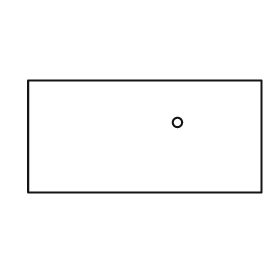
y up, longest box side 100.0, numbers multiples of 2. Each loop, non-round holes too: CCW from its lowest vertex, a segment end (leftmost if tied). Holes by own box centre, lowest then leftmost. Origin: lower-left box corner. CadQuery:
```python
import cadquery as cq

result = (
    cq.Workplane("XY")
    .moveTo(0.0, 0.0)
    .lineTo(100.0, 0.0)
    .lineTo(100.0, 48.0)
    .lineTo(0.0, 48.0)
    .close()
    .moveTo(64.0, 30.0)
    .circle(2.0)
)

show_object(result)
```